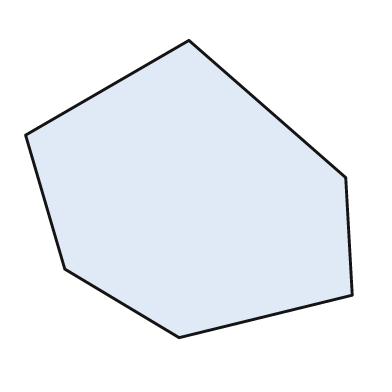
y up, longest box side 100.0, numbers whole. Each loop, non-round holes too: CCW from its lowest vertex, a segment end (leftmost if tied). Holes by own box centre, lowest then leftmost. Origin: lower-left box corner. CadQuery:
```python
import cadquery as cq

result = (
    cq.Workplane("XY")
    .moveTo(47.0, 0.0)
    .lineTo(100.0, 13.0)
    .lineTo(98.0, 49.0)
    .lineTo(50.0, 91.0)
    .lineTo(0.0, 62.0)
    .lineTo(12.0, 21.0)
    .close()
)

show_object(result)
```